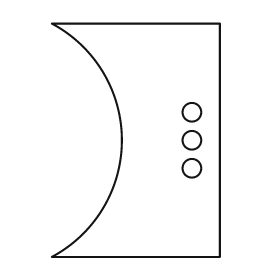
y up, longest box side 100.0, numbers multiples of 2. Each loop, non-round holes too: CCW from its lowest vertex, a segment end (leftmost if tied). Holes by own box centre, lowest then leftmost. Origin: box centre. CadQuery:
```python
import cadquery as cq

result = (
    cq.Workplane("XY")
    .moveTo(-36.0, -50.0)
    .lineTo(36.0, -50.0)
    .lineTo(36.0, 50.0)
    .lineTo(-36.0, 50.0)
    .threePointArc((-6.0, 0.0), (-36.0, -50.0))
    .close()
    .moveTo(24.0, -12.0)
    .circle(4.0)
    .moveTo(24.0, 0.0)
    .circle(4.0)
    .moveTo(24.0, 12.0)
    .circle(4.0)
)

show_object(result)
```